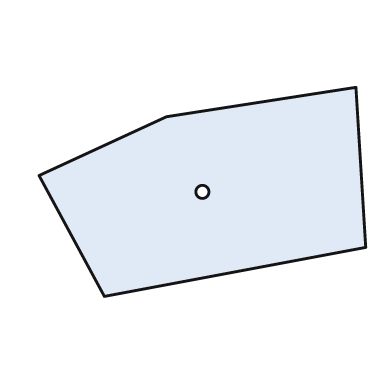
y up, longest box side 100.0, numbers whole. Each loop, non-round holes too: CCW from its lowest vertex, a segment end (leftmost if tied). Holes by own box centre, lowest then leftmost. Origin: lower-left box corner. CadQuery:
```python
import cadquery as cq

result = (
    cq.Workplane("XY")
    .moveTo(20.0, 0.0)
    .lineTo(100.0, 15.0)
    .lineTo(97.0, 64.0)
    .lineTo(39.0, 55.0)
    .lineTo(0.0, 37.0)
    .close()
    .moveTo(50.0, 32.0)
    .circle(2.0)
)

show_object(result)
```